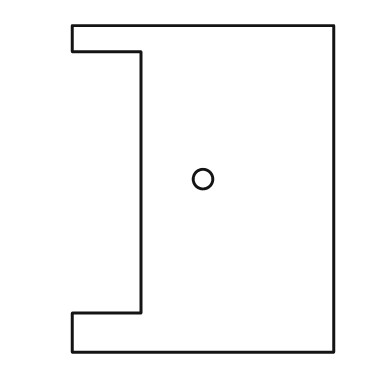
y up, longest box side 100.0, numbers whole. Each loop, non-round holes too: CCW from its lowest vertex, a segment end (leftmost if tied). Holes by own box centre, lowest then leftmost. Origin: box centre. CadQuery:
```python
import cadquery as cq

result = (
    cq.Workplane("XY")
    .moveTo(-40.0, -50.0)
    .lineTo(40.0, -50.0)
    .lineTo(40.0, 50.0)
    .lineTo(-40.0, 50.0)
    .lineTo(-40.0, 42.0)
    .lineTo(-19.0, 42.0)
    .lineTo(-19.0, -38.0)
    .lineTo(-40.0, -38.0)
    .close()
    .moveTo(0.0, 3.0)
    .circle(3.0)
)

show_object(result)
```